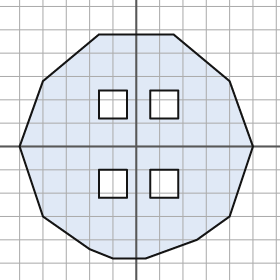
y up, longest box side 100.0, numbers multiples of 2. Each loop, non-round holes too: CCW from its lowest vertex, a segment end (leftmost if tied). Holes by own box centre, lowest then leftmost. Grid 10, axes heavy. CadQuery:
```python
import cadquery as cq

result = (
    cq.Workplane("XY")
    .moveTo(-10.0, -48.0)
    .lineTo(4.0, -48.0)
    .lineTo(26.0, -40.0)
    .lineTo(40.0, -30.0)
    .lineTo(50.0, 0.0)
    .lineTo(40.0, 28.0)
    .lineTo(16.0, 48.0)
    .lineTo(-16.0, 48.0)
    .lineTo(-40.0, 28.0)
    .lineTo(-50.0, 0.0)
    .lineTo(-40.0, -30.0)
    .lineTo(-20.0, -44.0)
    .close()
    .moveTo(-16.0, -22.0)
    .lineTo(-4.0, -22.0)
    .lineTo(-4.0, -10.0)
    .lineTo(-16.0, -10.0)
    .close()
    .moveTo(6.0, -22.0)
    .lineTo(18.0, -22.0)
    .lineTo(18.0, -10.0)
    .lineTo(6.0, -10.0)
    .close()
    .moveTo(-16.0, 12.0)
    .lineTo(-4.0, 12.0)
    .lineTo(-4.0, 24.0)
    .lineTo(-16.0, 24.0)
    .close()
    .moveTo(6.0, 12.0)
    .lineTo(18.0, 12.0)
    .lineTo(18.0, 24.0)
    .lineTo(6.0, 24.0)
    .close()
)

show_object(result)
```